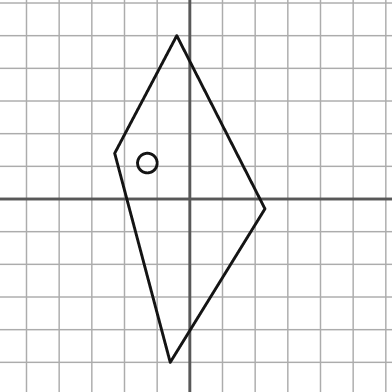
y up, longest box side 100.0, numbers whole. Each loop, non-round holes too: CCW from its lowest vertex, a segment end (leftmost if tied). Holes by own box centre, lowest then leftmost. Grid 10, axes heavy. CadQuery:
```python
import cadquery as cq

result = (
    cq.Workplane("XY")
    .moveTo(-6.0, -50.0)
    .lineTo(23.0, -3.0)
    .lineTo(-4.0, 50.0)
    .lineTo(-23.0, 14.0)
    .close()
    .moveTo(-13.0, 11.0)
    .circle(3.0)
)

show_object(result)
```